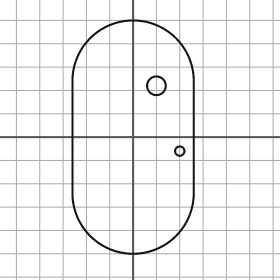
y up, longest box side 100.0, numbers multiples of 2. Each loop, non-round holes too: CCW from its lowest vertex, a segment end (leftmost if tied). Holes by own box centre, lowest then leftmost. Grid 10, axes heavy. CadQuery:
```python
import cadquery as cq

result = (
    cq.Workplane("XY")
    .moveTo(-26.0, -24.0)
    .threePointArc((0.0, -50.0), (26.0, -24.0))
    .lineTo(26.0, 24.0)
    .threePointArc((0.0, 50.0), (-26.0, 24.0))
    .close()
    .moveTo(20.0, -6.0)
    .circle(2.0)
    .moveTo(10.0, 22.0)
    .circle(4.0)
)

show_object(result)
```